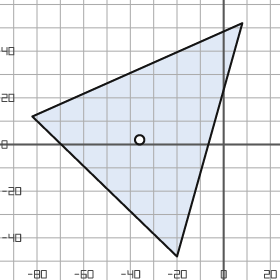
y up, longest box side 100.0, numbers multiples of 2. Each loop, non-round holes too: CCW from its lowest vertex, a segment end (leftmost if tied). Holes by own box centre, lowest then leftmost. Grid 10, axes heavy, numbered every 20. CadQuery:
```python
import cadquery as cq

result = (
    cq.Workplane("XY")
    .moveTo(-20.0, -48.0)
    .lineTo(8.0, 52.0)
    .lineTo(-82.0, 12.0)
    .close()
    .moveTo(-36.0, 2.0)
    .circle(2.0)
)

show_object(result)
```